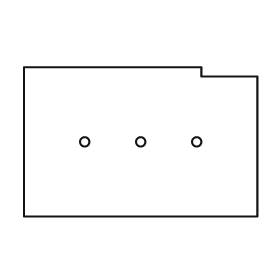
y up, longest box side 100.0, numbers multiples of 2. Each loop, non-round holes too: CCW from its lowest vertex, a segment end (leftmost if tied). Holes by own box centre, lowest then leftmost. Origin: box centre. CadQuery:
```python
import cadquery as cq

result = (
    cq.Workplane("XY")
    .moveTo(-50.0, -32.0)
    .lineTo(50.0, -32.0)
    .lineTo(50.0, 28.0)
    .lineTo(26.0, 28.0)
    .lineTo(26.0, 32.0)
    .lineTo(-50.0, 32.0)
    .close()
    .moveTo(-24.0, 0.0)
    .circle(2.0)
    .moveTo(0.0, 0.0)
    .circle(2.0)
    .moveTo(24.0, 0.0)
    .circle(2.0)
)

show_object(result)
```